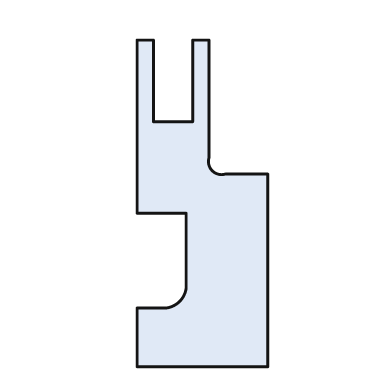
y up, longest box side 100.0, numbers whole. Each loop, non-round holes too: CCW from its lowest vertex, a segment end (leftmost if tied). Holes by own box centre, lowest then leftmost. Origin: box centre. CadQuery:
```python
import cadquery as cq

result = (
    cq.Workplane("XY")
    .moveTo(-20.0, -50.0)
    .lineTo(20.0, -50.0)
    .lineTo(20.0, 9.0)
    .lineTo(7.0, 9.0)
    .threePointArc((3.0, 10.0), (2.0, 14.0))
    .lineTo(2.0, 50.0)
    .lineTo(-3.0, 50.0)
    .lineTo(-3.0, 25.0)
    .lineTo(-15.0, 25.0)
    .lineTo(-15.0, 50.0)
    .lineTo(-20.0, 50.0)
    .lineTo(-20.0, -3.0)
    .lineTo(-5.0, -3.0)
    .lineTo(-5.0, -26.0)
    .threePointArc((-7.0, -30.0), (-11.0, -32.0))
    .lineTo(-20.0, -32.0)
    .close()
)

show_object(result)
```